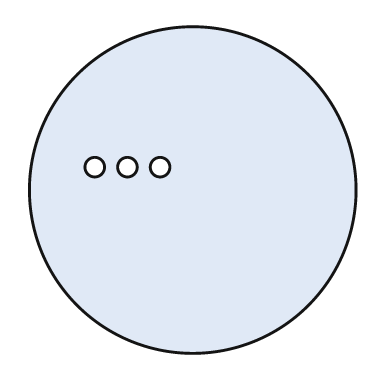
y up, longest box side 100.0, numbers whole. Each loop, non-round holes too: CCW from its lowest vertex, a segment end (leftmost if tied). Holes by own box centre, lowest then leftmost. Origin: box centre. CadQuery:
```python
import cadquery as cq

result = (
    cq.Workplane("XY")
    .moveTo(0.0, 0.0)
    .circle(50.0)
    .moveTo(-30.0, 7.0)
    .circle(3.0)
    .moveTo(-20.0, 7.0)
    .circle(3.0)
    .moveTo(-10.0, 7.0)
    .circle(3.0)
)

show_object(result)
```